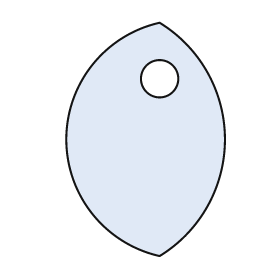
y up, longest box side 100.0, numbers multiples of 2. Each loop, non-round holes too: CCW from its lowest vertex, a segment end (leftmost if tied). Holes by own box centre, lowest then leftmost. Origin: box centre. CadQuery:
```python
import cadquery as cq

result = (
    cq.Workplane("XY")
    .moveTo(6.0, -50.0)
    .threePointArc((34.0, 0.0), (6.0, 50.0))
    .threePointArc((-34.0, 0.0), (6.0, -50.0))
    .close()
    .moveTo(6.0, 26.0)
    .circle(8.0)
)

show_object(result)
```